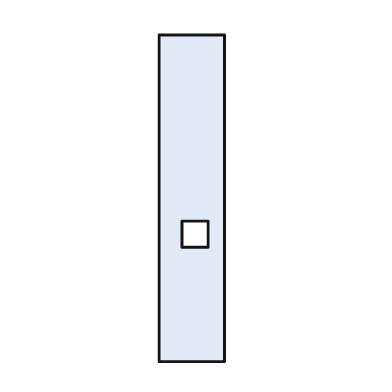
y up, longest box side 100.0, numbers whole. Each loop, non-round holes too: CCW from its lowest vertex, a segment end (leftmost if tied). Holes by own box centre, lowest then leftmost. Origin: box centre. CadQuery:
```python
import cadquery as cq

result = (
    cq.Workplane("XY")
    .moveTo(-10.0, -50.0)
    .lineTo(10.0, -50.0)
    .lineTo(10.0, 50.0)
    .lineTo(-10.0, 50.0)
    .close()
    .moveTo(-3.0, -15.0)
    .lineTo(5.0, -15.0)
    .lineTo(5.0, -7.0)
    .lineTo(-3.0, -7.0)
    .close()
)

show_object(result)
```